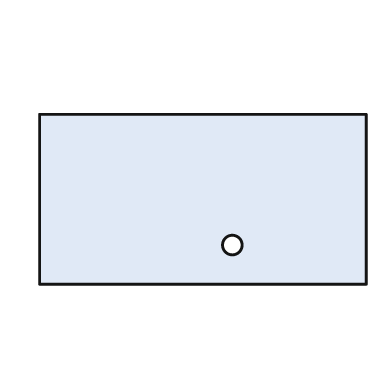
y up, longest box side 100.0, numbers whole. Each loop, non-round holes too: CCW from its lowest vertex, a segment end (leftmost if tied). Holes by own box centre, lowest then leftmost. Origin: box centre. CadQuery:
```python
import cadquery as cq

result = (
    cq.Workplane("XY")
    .moveTo(-50.0, -26.0)
    .lineTo(50.0, -26.0)
    .lineTo(50.0, 26.0)
    .lineTo(-50.0, 26.0)
    .close()
    .moveTo(9.0, -14.0)
    .circle(3.0)
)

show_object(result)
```